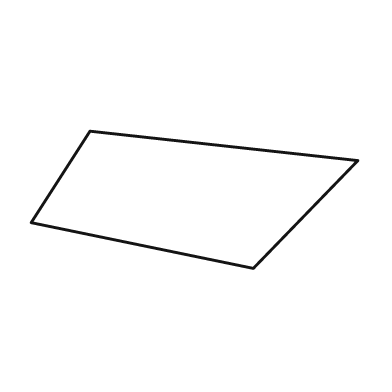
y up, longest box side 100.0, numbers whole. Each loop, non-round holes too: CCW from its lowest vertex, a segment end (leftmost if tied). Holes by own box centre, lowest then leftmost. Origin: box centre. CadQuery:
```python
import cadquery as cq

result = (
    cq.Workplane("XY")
    .moveTo(18.0, -21.0)
    .lineTo(50.0, 12.0)
    .lineTo(-32.0, 21.0)
    .lineTo(-50.0, -7.0)
    .close()
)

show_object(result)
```